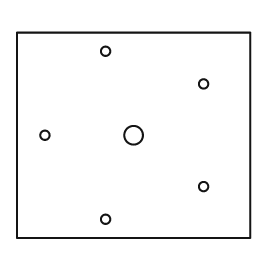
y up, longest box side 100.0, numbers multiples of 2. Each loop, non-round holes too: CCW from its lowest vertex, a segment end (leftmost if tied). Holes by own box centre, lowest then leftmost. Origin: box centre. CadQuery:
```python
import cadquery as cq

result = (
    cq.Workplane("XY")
    .moveTo(-50.0, -44.0)
    .lineTo(50.0, -44.0)
    .lineTo(50.0, 44.0)
    .lineTo(-50.0, 44.0)
    .close()
    .moveTo(-12.0, -36.0)
    .circle(2.0)
    .moveTo(30.0, -22.0)
    .circle(2.0)
    .moveTo(-38.0, 0.0)
    .circle(2.0)
    .moveTo(0.0, 0.0)
    .circle(4.0)
    .moveTo(30.0, 22.0)
    .circle(2.0)
    .moveTo(-12.0, 36.0)
    .circle(2.0)
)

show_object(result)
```